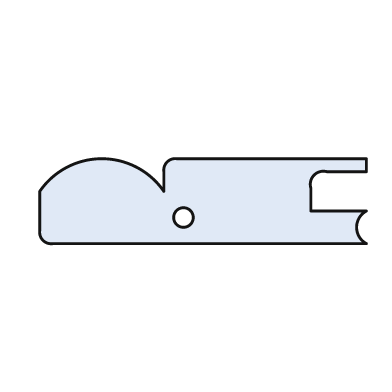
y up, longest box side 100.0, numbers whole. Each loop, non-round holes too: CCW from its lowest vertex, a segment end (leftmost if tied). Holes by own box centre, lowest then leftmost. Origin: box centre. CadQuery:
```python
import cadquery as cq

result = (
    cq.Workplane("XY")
    .moveTo(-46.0, -13.0)
    .lineTo(50.0, -13.0)
    .threePointArc((47.0, -8.0), (50.0, -3.0))
    .lineTo(33.0, -3.0)
    .lineTo(33.0, 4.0)
    .threePointArc((34.0, 8.0), (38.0, 9.0))
    .lineTo(50.0, 9.0)
    .lineTo(50.0, 13.0)
    .lineTo(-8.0, 13.0)
    .threePointArc((-11.0, 12.0), (-12.0, 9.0))
    .lineTo(-12.0, 3.0)
    .threePointArc((-31.0, 13.0), (-50.0, 3.0))
    .lineTo(-50.0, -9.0)
    .threePointArc((-49.0, -12.0), (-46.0, -13.0))
    .close()
    .moveTo(-6.0, -5.0)
    .circle(3.0)
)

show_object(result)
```